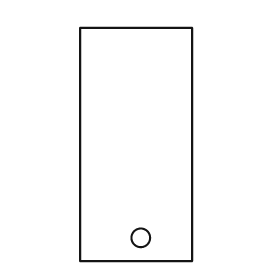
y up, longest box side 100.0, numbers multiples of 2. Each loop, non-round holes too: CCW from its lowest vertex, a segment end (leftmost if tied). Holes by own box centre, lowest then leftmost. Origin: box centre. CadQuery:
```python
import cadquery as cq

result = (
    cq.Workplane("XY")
    .moveTo(-24.0, -50.0)
    .lineTo(24.0, -50.0)
    .lineTo(24.0, 50.0)
    .lineTo(-24.0, 50.0)
    .close()
    .moveTo(2.0, -40.0)
    .circle(4.0)
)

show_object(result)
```